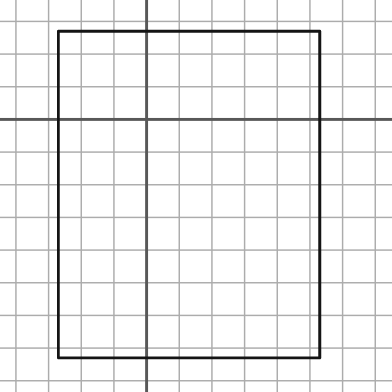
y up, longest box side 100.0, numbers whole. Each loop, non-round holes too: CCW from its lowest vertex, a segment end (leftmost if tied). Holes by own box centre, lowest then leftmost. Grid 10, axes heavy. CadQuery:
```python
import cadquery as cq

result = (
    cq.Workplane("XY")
    .moveTo(-27.0, -73.0)
    .lineTo(53.0, -73.0)
    .lineTo(53.0, 27.0)
    .lineTo(-27.0, 27.0)
    .close()
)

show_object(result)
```